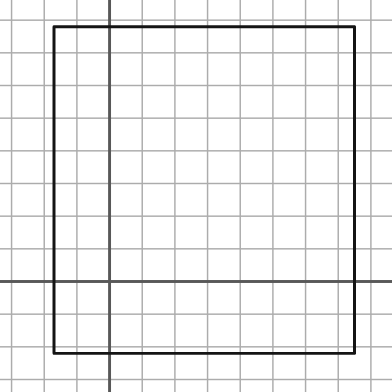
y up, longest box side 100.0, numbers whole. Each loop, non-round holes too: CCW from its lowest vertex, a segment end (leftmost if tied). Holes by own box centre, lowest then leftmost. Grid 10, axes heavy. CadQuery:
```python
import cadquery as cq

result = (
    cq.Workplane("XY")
    .moveTo(-17.0, -22.0)
    .lineTo(75.0, -22.0)
    .lineTo(75.0, 78.0)
    .lineTo(-17.0, 78.0)
    .close()
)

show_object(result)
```